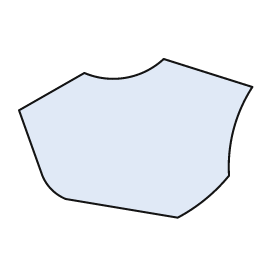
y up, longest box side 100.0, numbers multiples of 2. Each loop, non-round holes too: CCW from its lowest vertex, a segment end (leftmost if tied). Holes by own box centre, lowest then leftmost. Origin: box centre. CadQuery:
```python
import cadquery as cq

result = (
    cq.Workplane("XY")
    .moveTo(18.0, -34.0)
    .threePointArc((30.0, -26.0), (40.0, -16.0))
    .threePointArc((42.0, 4.0), (50.0, 22.0))
    .lineTo(12.0, 34.0)
    .threePointArc((-4.0, 26.0), (-22.0, 28.0))
    .lineTo(-50.0, 12.0)
    .lineTo(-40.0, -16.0)
    .threePointArc((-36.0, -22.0), (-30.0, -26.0))
    .close()
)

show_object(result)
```